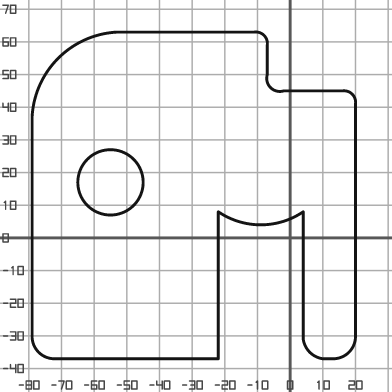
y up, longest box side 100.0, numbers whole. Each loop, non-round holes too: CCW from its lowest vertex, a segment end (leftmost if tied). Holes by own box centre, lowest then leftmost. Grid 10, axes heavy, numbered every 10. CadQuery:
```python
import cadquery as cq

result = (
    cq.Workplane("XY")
    .moveTo(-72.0, -37.0)
    .lineTo(-22.0, -37.0)
    .lineTo(-22.0, 8.0)
    .threePointArc((-9.0, 4.0), (4.0, 8.0))
    .lineTo(4.0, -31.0)
    .threePointArc((6.0, -35.0), (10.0, -37.0))
    .lineTo(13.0, -37.0)
    .threePointArc((18.0, -35.0), (20.0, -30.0))
    .lineTo(20.0, 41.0)
    .threePointArc((19.0, 44.0), (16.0, 45.0))
    .lineTo(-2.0, 45.0)
    .threePointArc((-6.0, 46.0), (-7.0, 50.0))
    .lineTo(-7.0, 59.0)
    .threePointArc((-8.0, 62.0), (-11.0, 63.0))
    .lineTo(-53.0, 63.0)
    .threePointArc((-71.0, 55.0), (-79.0, 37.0))
    .lineTo(-79.0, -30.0)
    .threePointArc((-77.0, -35.0), (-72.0, -37.0))
    .close()
    .moveTo(-55.0, 17.0)
    .circle(10.0)
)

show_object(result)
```